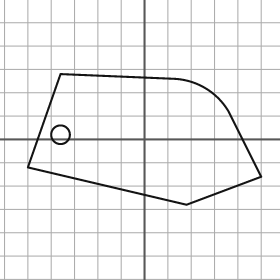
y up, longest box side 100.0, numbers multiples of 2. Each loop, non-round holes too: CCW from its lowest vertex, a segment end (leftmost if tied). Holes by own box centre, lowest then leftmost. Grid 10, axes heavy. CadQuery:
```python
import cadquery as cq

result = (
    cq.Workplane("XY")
    .moveTo(18.0, -28.0)
    .lineTo(50.0, -16.0)
    .lineTo(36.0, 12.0)
    .threePointArc((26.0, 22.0), (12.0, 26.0))
    .lineTo(-36.0, 28.0)
    .lineTo(-50.0, -12.0)
    .close()
    .moveTo(-36.0, 2.0)
    .circle(4.0)
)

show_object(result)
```